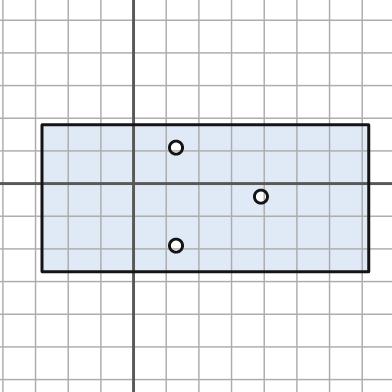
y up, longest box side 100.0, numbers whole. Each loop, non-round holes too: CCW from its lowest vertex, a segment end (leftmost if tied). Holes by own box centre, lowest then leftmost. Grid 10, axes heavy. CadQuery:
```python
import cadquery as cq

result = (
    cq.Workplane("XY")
    .moveTo(-28.0, -27.0)
    .lineTo(72.0, -27.0)
    .lineTo(72.0, 18.0)
    .lineTo(-28.0, 18.0)
    .close()
    .moveTo(13.0, -19.0)
    .circle(2.0)
    .moveTo(39.0, -4.0)
    .circle(2.0)
    .moveTo(13.0, 11.0)
    .circle(2.0)
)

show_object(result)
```